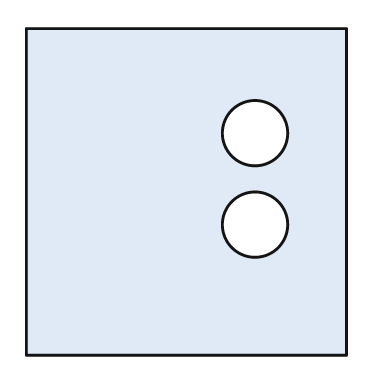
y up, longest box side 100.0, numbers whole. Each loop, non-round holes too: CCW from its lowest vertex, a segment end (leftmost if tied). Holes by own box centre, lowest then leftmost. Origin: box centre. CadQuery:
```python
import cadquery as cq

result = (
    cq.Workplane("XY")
    .moveTo(-49.0, -50.0)
    .lineTo(49.0, -50.0)
    .lineTo(49.0, 50.0)
    .lineTo(-49.0, 50.0)
    .close()
    .moveTo(21.0, -10.0)
    .circle(10.0)
    .moveTo(21.0, 18.0)
    .circle(10.0)
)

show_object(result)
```